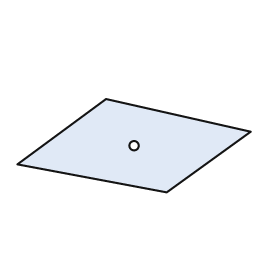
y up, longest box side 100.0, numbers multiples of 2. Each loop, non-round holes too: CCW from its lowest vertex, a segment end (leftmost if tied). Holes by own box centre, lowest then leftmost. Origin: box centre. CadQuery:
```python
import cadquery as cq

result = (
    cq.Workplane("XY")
    .moveTo(14.0, -20.0)
    .lineTo(50.0, 6.0)
    .lineTo(-12.0, 20.0)
    .lineTo(-50.0, -8.0)
    .close()
    .moveTo(0.0, 0.0)
    .circle(2.0)
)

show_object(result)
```